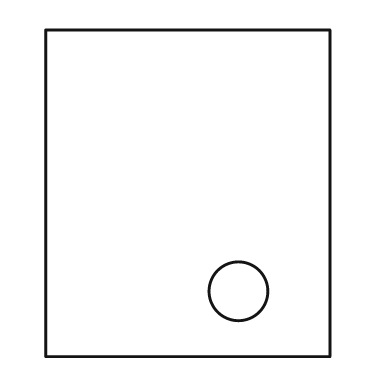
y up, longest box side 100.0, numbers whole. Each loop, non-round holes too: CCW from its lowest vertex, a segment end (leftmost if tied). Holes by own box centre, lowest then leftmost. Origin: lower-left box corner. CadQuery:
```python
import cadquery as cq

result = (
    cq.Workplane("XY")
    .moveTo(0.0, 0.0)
    .lineTo(87.0, 0.0)
    .lineTo(87.0, 100.0)
    .lineTo(0.0, 100.0)
    .close()
    .moveTo(59.0, 20.0)
    .circle(9.0)
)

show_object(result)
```